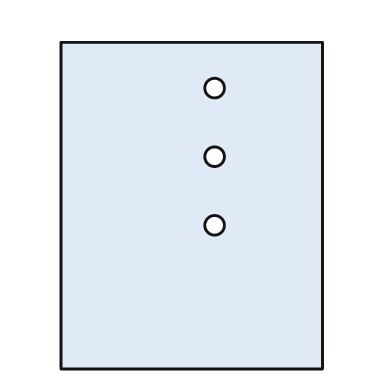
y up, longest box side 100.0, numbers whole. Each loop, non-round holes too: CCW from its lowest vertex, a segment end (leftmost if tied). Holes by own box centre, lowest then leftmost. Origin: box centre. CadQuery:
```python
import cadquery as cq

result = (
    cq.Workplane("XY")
    .moveTo(-40.0, -50.0)
    .lineTo(40.0, -50.0)
    .lineTo(40.0, 50.0)
    .lineTo(-40.0, 50.0)
    .close()
    .moveTo(7.0, -6.0)
    .circle(3.0)
    .moveTo(7.0, 15.0)
    .circle(3.0)
    .moveTo(7.0, 36.0)
    .circle(3.0)
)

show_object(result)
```